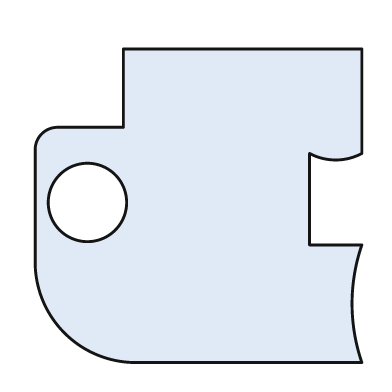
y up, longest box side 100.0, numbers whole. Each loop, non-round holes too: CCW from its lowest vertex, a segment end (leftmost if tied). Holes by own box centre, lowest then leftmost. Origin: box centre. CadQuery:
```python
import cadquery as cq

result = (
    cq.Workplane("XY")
    .moveTo(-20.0, -48.0)
    .lineTo(50.0, -48.0)
    .threePointArc((47.0, -30.0), (50.0, -12.0))
    .lineTo(34.0, -12.0)
    .lineTo(34.0, 16.0)
    .threePointArc((42.0, 14.0), (50.0, 16.0))
    .lineTo(50.0, 48.0)
    .lineTo(-23.0, 48.0)
    .lineTo(-23.0, 24.0)
    .lineTo(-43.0, 24.0)
    .threePointArc((-48.0, 22.0), (-50.0, 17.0))
    .lineTo(-50.0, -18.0)
    .threePointArc((-41.0, -39.0), (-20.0, -48.0))
    .close()
    .moveTo(-34.0, 1.0)
    .circle(12.0)
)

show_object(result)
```